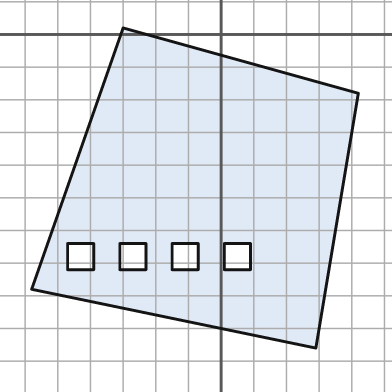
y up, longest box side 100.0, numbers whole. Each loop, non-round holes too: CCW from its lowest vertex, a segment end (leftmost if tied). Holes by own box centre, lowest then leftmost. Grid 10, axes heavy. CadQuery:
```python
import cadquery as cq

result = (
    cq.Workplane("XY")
    .moveTo(29.0, -96.0)
    .lineTo(42.0, -18.0)
    .lineTo(-30.0, 2.0)
    .lineTo(-58.0, -78.0)
    .close()
    .moveTo(-47.0, -72.0)
    .lineTo(-39.0, -72.0)
    .lineTo(-39.0, -64.0)
    .lineTo(-47.0, -64.0)
    .close()
    .moveTo(-31.0, -72.0)
    .lineTo(-23.0, -72.0)
    .lineTo(-23.0, -64.0)
    .lineTo(-31.0, -64.0)
    .close()
    .moveTo(-15.0, -72.0)
    .lineTo(-7.0, -72.0)
    .lineTo(-7.0, -64.0)
    .lineTo(-15.0, -64.0)
    .close()
    .moveTo(1.0, -72.0)
    .lineTo(9.0, -72.0)
    .lineTo(9.0, -64.0)
    .lineTo(1.0, -64.0)
    .close()
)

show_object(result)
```